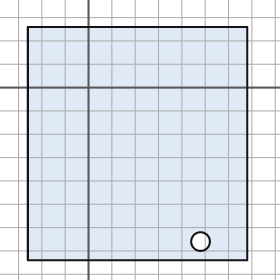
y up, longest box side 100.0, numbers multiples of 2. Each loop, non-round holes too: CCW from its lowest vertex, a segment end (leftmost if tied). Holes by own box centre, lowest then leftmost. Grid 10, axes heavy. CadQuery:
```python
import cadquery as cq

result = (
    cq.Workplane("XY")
    .moveTo(-26.0, -74.0)
    .lineTo(68.0, -74.0)
    .lineTo(68.0, 26.0)
    .lineTo(-26.0, 26.0)
    .close()
    .moveTo(48.0, -66.0)
    .circle(4.0)
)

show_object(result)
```